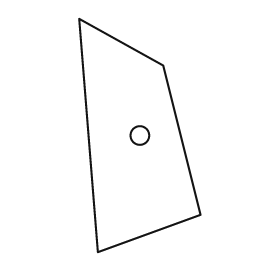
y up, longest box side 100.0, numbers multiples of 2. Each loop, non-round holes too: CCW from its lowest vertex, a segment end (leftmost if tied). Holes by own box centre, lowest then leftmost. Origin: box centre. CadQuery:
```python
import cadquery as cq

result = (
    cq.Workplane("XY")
    .moveTo(-18.0, -50.0)
    .lineTo(26.0, -34.0)
    .lineTo(10.0, 30.0)
    .lineTo(-26.0, 50.0)
    .close()
    .moveTo(0.0, 0.0)
    .circle(4.0)
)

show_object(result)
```